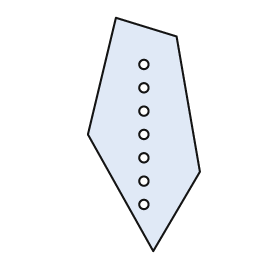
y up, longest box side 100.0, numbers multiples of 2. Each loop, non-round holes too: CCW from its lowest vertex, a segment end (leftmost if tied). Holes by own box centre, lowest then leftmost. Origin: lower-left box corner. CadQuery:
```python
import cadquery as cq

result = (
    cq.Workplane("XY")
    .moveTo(28.0, 0.0)
    .lineTo(48.0, 34.0)
    .lineTo(38.0, 92.0)
    .lineTo(12.0, 100.0)
    .lineTo(0.0, 50.0)
    .close()
    .moveTo(24.0, 20.0)
    .circle(2.0)
    .moveTo(24.0, 30.0)
    .circle(2.0)
    .moveTo(24.0, 40.0)
    .circle(2.0)
    .moveTo(24.0, 50.0)
    .circle(2.0)
    .moveTo(24.0, 60.0)
    .circle(2.0)
    .moveTo(24.0, 70.0)
    .circle(2.0)
    .moveTo(24.0, 80.0)
    .circle(2.0)
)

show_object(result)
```